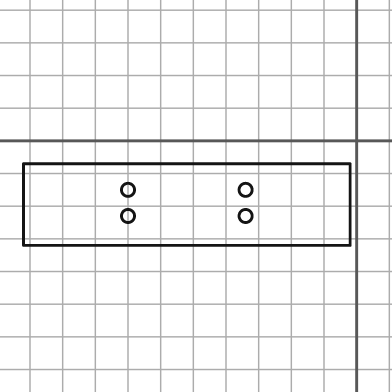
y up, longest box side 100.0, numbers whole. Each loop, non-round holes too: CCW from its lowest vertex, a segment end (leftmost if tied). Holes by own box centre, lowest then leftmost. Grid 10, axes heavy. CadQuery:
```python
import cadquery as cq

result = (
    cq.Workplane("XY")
    .moveTo(-102.0, -32.0)
    .lineTo(-2.0, -32.0)
    .lineTo(-2.0, -7.0)
    .lineTo(-102.0, -7.0)
    .close()
    .moveTo(-70.0, -23.0)
    .circle(2.0)
    .moveTo(-34.0, -23.0)
    .circle(2.0)
    .moveTo(-70.0, -15.0)
    .circle(2.0)
    .moveTo(-34.0, -15.0)
    .circle(2.0)
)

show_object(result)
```